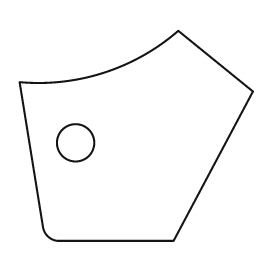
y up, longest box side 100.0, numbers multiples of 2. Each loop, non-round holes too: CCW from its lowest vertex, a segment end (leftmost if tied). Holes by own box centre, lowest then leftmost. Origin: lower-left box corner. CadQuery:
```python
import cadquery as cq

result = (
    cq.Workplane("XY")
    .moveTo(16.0, 0.0)
    .lineTo(66.0, 0.0)
    .lineTo(100.0, 64.0)
    .lineTo(68.0, 90.0)
    .threePointArc((36.0, 72.0), (0.0, 68.0))
    .lineTo(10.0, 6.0)
    .threePointArc((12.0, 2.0), (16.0, 0.0))
    .close()
    .moveTo(24.0, 42.0)
    .circle(8.0)
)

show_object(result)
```